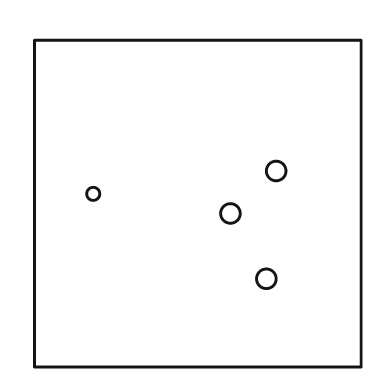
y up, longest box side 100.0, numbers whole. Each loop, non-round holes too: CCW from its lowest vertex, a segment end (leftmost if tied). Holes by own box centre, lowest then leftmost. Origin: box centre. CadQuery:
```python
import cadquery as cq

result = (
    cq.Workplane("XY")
    .moveTo(-50.0, -50.0)
    .lineTo(50.0, -50.0)
    .lineTo(50.0, 50.0)
    .lineTo(-50.0, 50.0)
    .close()
    .moveTo(21.0, -23.0)
    .circle(3.0)
    .moveTo(10.0, -3.0)
    .circle(3.0)
    .moveTo(-32.0, 3.0)
    .circle(2.0)
    .moveTo(24.0, 10.0)
    .circle(3.0)
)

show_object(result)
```